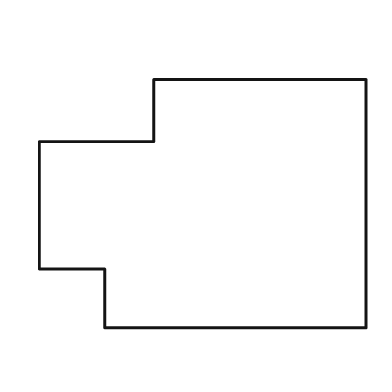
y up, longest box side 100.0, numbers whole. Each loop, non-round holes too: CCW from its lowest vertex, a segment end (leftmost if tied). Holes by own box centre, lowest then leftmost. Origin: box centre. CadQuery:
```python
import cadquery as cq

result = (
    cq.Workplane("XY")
    .moveTo(-30.0, -38.0)
    .lineTo(50.0, -38.0)
    .lineTo(50.0, 38.0)
    .lineTo(-15.0, 38.0)
    .lineTo(-15.0, 19.0)
    .lineTo(-50.0, 19.0)
    .lineTo(-50.0, -20.0)
    .lineTo(-30.0, -20.0)
    .close()
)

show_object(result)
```